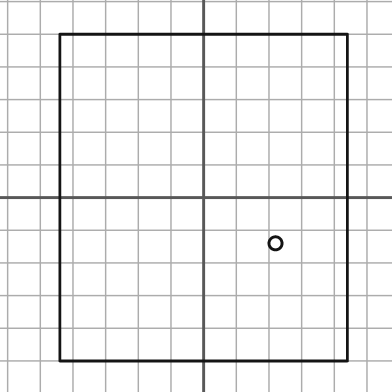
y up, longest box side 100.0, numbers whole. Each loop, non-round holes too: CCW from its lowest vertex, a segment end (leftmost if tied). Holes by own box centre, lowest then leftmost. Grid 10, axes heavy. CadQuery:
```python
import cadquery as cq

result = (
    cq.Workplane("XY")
    .moveTo(-44.0, -50.0)
    .lineTo(44.0, -50.0)
    .lineTo(44.0, 50.0)
    .lineTo(-44.0, 50.0)
    .close()
    .moveTo(22.0, -14.0)
    .circle(2.0)
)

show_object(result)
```